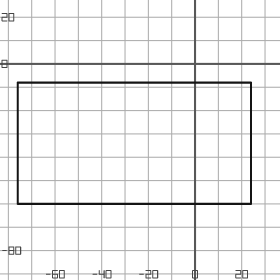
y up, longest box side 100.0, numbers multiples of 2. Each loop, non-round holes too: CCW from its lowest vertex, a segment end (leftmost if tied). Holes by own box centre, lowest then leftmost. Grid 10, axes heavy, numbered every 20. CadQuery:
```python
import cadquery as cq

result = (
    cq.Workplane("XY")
    .moveTo(-76.0, -60.0)
    .lineTo(24.0, -60.0)
    .lineTo(24.0, -8.0)
    .lineTo(-76.0, -8.0)
    .close()
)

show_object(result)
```